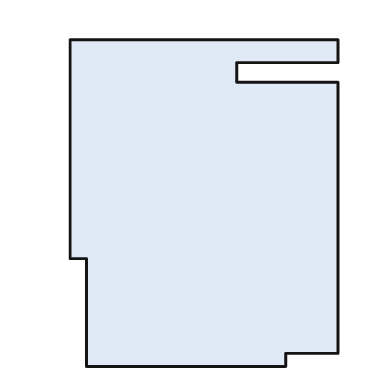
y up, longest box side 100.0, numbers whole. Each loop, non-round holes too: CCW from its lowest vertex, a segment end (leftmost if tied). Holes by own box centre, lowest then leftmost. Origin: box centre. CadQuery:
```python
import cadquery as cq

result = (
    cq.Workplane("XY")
    .moveTo(-36.0, -50.0)
    .lineTo(25.0, -50.0)
    .lineTo(25.0, -46.0)
    .lineTo(41.0, -46.0)
    .lineTo(41.0, 37.0)
    .lineTo(10.0, 37.0)
    .lineTo(10.0, 43.0)
    .lineTo(41.0, 43.0)
    .lineTo(41.0, 50.0)
    .lineTo(-41.0, 50.0)
    .lineTo(-41.0, -17.0)
    .lineTo(-36.0, -17.0)
    .close()
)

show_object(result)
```